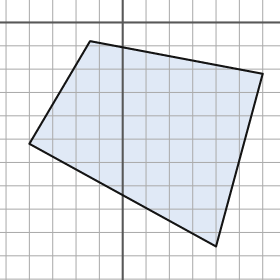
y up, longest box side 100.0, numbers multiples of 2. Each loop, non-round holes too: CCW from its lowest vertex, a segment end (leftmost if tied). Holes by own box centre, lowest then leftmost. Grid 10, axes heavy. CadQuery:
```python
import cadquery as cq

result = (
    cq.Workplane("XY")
    .moveTo(40.0, -96.0)
    .lineTo(60.0, -22.0)
    .lineTo(-14.0, -8.0)
    .lineTo(-40.0, -52.0)
    .close()
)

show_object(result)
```